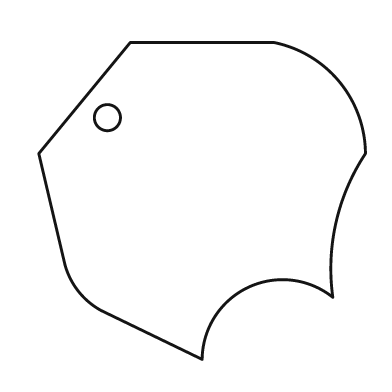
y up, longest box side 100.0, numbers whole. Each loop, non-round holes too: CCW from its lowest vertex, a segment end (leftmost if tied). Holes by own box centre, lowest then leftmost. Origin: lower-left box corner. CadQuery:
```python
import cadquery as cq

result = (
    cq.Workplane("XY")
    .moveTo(50.0, 0.0)
    .threePointArc((64.0, 22.0), (90.0, 19.0))
    .threePointArc((91.0, 42.0), (100.0, 63.0))
    .threePointArc((92.0, 85.0), (72.0, 97.0))
    .lineTo(28.0, 97.0)
    .lineTo(0.0, 63.0)
    .lineTo(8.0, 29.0)
    .threePointArc((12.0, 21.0), (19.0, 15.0))
    .close()
    .moveTo(21.0, 74.0)
    .circle(4.0)
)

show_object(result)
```